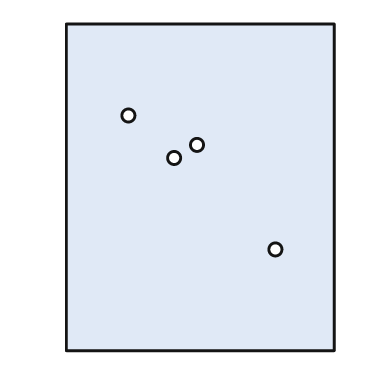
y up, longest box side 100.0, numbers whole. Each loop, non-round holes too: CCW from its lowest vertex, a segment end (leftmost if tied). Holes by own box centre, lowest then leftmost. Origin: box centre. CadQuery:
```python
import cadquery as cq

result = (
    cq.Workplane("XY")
    .moveTo(-41.0, -50.0)
    .lineTo(41.0, -50.0)
    .lineTo(41.0, 50.0)
    .lineTo(-41.0, 50.0)
    .close()
    .moveTo(23.0, -19.0)
    .circle(2.0)
    .moveTo(-8.0, 9.0)
    .circle(2.0)
    .moveTo(-1.0, 13.0)
    .circle(2.0)
    .moveTo(-22.0, 22.0)
    .circle(2.0)
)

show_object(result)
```